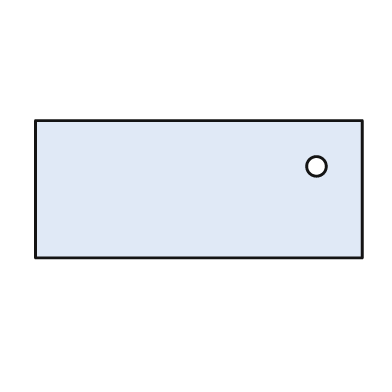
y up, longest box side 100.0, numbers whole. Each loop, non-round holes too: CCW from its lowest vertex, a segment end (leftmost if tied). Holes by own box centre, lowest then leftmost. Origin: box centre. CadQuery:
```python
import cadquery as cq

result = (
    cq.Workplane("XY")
    .moveTo(-50.0, -21.0)
    .lineTo(50.0, -21.0)
    .lineTo(50.0, 21.0)
    .lineTo(-50.0, 21.0)
    .close()
    .moveTo(36.0, 7.0)
    .circle(3.0)
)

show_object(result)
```